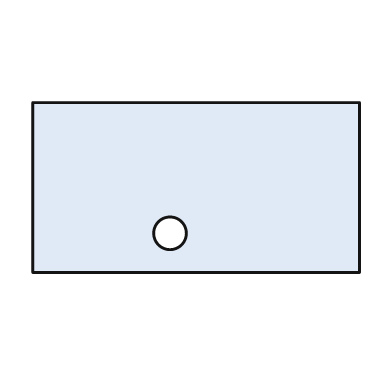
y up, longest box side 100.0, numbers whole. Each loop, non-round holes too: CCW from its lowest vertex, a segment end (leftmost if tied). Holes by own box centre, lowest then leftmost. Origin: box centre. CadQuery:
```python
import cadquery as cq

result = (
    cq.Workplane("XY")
    .moveTo(-50.0, -26.0)
    .lineTo(50.0, -26.0)
    .lineTo(50.0, 26.0)
    .lineTo(-50.0, 26.0)
    .close()
    .moveTo(-8.0, -14.0)
    .circle(5.0)
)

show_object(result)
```